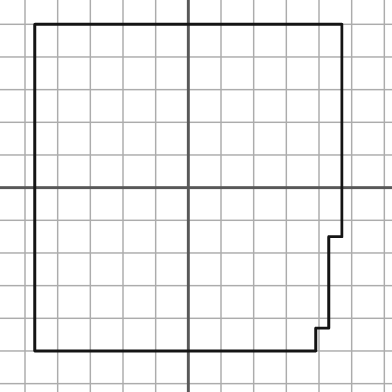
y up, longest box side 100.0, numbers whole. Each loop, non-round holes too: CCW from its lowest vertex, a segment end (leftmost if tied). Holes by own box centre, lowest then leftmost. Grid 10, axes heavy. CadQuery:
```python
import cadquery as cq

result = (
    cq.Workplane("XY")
    .moveTo(-47.0, -50.0)
    .lineTo(39.0, -50.0)
    .lineTo(39.0, -43.0)
    .lineTo(43.0, -43.0)
    .lineTo(43.0, -15.0)
    .lineTo(47.0, -15.0)
    .lineTo(47.0, 50.0)
    .lineTo(-47.0, 50.0)
    .close()
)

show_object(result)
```